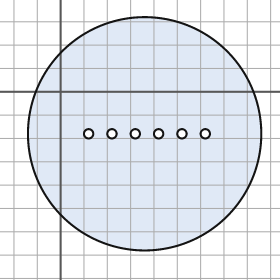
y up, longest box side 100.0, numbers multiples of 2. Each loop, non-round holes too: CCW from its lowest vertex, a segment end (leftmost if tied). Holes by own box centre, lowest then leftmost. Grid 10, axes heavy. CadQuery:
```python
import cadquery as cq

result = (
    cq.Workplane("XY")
    .moveTo(36.0, -18.0)
    .circle(50.0)
    .moveTo(12.0, -18.0)
    .circle(2.0)
    .moveTo(22.0, -18.0)
    .circle(2.0)
    .moveTo(32.0, -18.0)
    .circle(2.0)
    .moveTo(42.0, -18.0)
    .circle(2.0)
    .moveTo(52.0, -18.0)
    .circle(2.0)
    .moveTo(62.0, -18.0)
    .circle(2.0)
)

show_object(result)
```